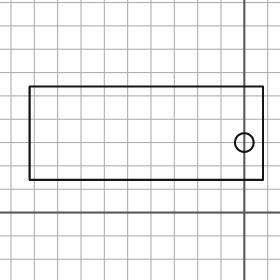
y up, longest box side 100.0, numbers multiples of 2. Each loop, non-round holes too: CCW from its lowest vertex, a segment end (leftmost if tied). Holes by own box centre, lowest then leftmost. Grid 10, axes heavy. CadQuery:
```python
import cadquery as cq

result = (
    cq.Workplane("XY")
    .moveTo(-92.0, 14.0)
    .lineTo(8.0, 14.0)
    .lineTo(8.0, 54.0)
    .lineTo(-92.0, 54.0)
    .close()
    .moveTo(0.0, 30.0)
    .circle(4.0)
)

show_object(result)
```